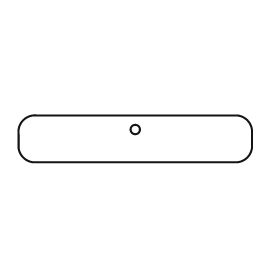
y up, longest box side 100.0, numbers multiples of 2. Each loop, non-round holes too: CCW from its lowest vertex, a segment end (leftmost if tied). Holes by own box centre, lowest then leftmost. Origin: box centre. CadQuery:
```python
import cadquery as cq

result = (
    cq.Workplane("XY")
    .moveTo(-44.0, -10.0)
    .lineTo(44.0, -10.0)
    .threePointArc((48.0, -8.0), (50.0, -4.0))
    .lineTo(50.0, 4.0)
    .threePointArc((48.0, 8.0), (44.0, 10.0))
    .lineTo(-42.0, 10.0)
    .threePointArc((-48.0, 8.0), (-50.0, 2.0))
    .lineTo(-50.0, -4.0)
    .threePointArc((-48.0, -8.0), (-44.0, -10.0))
    .close()
    .moveTo(0.0, 4.0)
    .circle(2.0)
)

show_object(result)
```